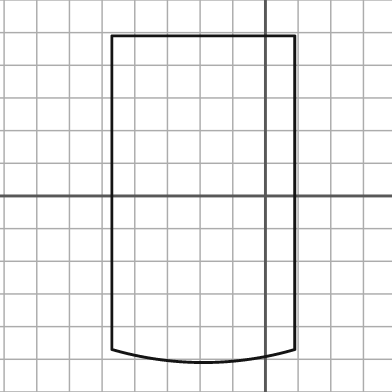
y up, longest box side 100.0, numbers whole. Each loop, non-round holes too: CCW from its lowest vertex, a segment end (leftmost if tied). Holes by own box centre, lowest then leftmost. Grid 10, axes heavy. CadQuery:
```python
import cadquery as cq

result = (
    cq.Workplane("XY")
    .moveTo(-47.0, -47.0)
    .threePointArc((-19.0, -51.0), (9.0, -47.0))
    .lineTo(9.0, 49.0)
    .lineTo(-47.0, 49.0)
    .close()
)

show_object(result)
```